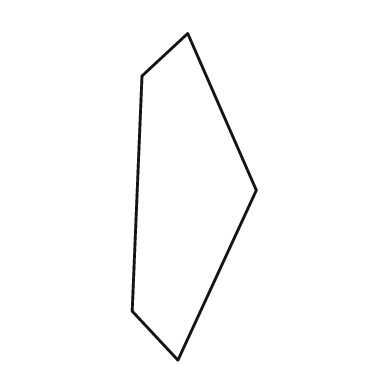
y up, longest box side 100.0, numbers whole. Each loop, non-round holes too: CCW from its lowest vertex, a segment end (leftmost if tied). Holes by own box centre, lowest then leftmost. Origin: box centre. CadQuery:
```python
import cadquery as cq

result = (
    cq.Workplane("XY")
    .moveTo(-5.0, -50.0)
    .lineTo(19.0, 2.0)
    .lineTo(-2.0, 50.0)
    .lineTo(-16.0, 37.0)
    .lineTo(-19.0, -35.0)
    .close()
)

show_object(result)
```